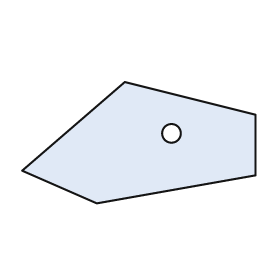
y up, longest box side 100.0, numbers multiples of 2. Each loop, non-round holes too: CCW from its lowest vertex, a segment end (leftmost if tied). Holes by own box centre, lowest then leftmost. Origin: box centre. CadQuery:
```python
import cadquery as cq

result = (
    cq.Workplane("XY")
    .moveTo(-18.0, -26.0)
    .lineTo(50.0, -14.0)
    .lineTo(50.0, 12.0)
    .lineTo(-6.0, 26.0)
    .lineTo(-50.0, -12.0)
    .close()
    .moveTo(14.0, 4.0)
    .circle(4.0)
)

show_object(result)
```